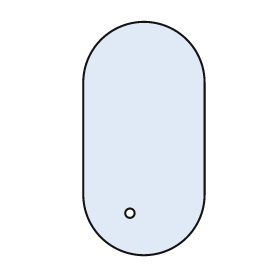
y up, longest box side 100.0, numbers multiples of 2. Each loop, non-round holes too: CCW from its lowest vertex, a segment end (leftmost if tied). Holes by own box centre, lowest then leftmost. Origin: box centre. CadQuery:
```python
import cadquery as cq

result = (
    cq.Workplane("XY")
    .moveTo(-26.0, -24.0)
    .threePointArc((0.0, -50.0), (26.0, -24.0))
    .lineTo(26.0, 24.0)
    .threePointArc((0.0, 50.0), (-26.0, 24.0))
    .close()
    .moveTo(-6.0, -32.0)
    .circle(2.0)
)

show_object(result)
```